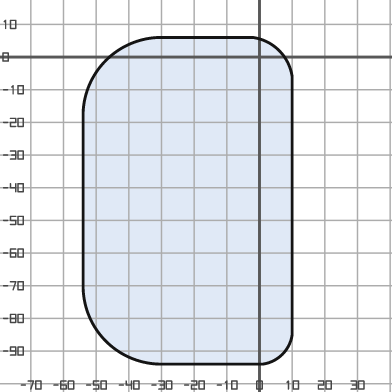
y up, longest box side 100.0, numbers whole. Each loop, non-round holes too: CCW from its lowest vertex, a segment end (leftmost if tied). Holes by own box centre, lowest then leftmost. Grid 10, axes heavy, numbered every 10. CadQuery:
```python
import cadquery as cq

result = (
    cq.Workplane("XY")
    .moveTo(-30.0, -94.0)
    .lineTo(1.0, -94.0)
    .threePointArc((7.0, -91.0), (10.0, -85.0))
    .lineTo(10.0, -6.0)
    .threePointArc((6.0, 2.0), (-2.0, 6.0))
    .lineTo(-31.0, 6.0)
    .threePointArc((-47.0, -1.0), (-54.0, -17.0))
    .lineTo(-54.0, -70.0)
    .threePointArc((-47.0, -87.0), (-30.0, -94.0))
    .close()
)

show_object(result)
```